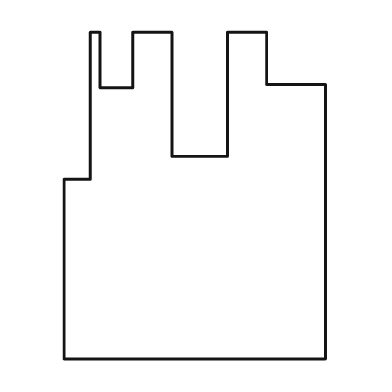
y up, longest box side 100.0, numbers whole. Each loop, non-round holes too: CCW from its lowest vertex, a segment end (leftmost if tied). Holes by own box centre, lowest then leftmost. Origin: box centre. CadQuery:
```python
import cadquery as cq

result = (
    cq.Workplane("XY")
    .moveTo(-40.0, -50.0)
    .lineTo(40.0, -50.0)
    .lineTo(40.0, 34.0)
    .lineTo(22.0, 34.0)
    .lineTo(22.0, 50.0)
    .lineTo(10.0, 50.0)
    .lineTo(10.0, 12.0)
    .lineTo(-7.0, 12.0)
    .lineTo(-7.0, 50.0)
    .lineTo(-19.0, 50.0)
    .lineTo(-19.0, 33.0)
    .lineTo(-29.0, 33.0)
    .lineTo(-29.0, 50.0)
    .lineTo(-32.0, 50.0)
    .lineTo(-32.0, 5.0)
    .lineTo(-40.0, 5.0)
    .close()
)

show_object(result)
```